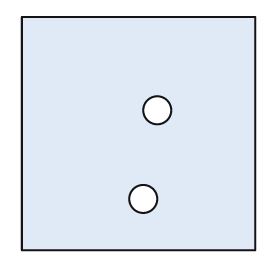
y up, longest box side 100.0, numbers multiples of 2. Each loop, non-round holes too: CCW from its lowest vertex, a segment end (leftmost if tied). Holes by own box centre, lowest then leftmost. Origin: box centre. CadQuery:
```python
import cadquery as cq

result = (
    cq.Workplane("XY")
    .moveTo(-50.0, -50.0)
    .lineTo(50.0, -50.0)
    .lineTo(50.0, 50.0)
    .lineTo(-50.0, 50.0)
    .close()
    .moveTo(2.0, -28.0)
    .circle(6.0)
    .moveTo(8.0, 10.0)
    .circle(6.0)
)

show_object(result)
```